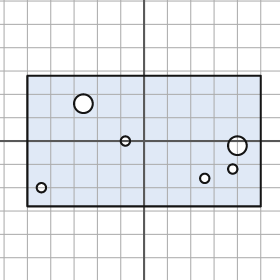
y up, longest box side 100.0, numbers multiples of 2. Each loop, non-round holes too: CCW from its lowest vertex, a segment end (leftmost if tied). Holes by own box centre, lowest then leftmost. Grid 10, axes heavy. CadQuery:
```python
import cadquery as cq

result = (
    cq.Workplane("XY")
    .moveTo(-50.0, -28.0)
    .lineTo(50.0, -28.0)
    .lineTo(50.0, 28.0)
    .lineTo(-50.0, 28.0)
    .close()
    .moveTo(-44.0, -20.0)
    .circle(2.0)
    .moveTo(26.0, -16.0)
    .circle(2.0)
    .moveTo(38.0, -12.0)
    .circle(2.0)
    .moveTo(40.0, -2.0)
    .circle(4.0)
    .moveTo(-8.0, 0.0)
    .circle(2.0)
    .moveTo(-26.0, 16.0)
    .circle(4.0)
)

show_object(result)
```